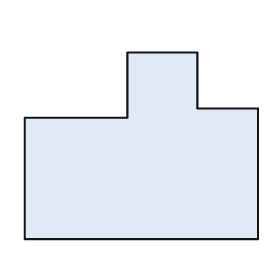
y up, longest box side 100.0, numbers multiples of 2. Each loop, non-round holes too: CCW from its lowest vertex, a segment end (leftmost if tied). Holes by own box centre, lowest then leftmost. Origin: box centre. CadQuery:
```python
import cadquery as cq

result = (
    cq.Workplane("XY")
    .moveTo(-50.0, -40.0)
    .lineTo(50.0, -40.0)
    .lineTo(50.0, 16.0)
    .lineTo(24.0, 16.0)
    .lineTo(24.0, 40.0)
    .lineTo(-6.0, 40.0)
    .lineTo(-6.0, 12.0)
    .lineTo(-50.0, 12.0)
    .close()
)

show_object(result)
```